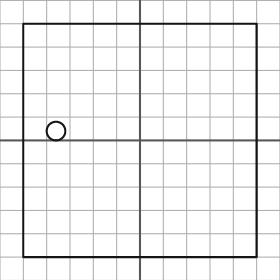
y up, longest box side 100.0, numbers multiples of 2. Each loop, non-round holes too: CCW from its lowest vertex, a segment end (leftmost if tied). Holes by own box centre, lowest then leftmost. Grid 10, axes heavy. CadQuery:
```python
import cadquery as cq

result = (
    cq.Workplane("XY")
    .moveTo(-50.0, -50.0)
    .lineTo(50.0, -50.0)
    .lineTo(50.0, 50.0)
    .lineTo(-50.0, 50.0)
    .close()
    .moveTo(-36.0, 4.0)
    .circle(4.0)
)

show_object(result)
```